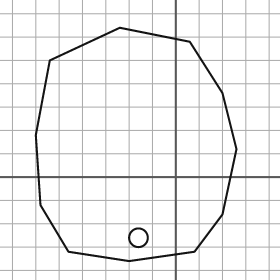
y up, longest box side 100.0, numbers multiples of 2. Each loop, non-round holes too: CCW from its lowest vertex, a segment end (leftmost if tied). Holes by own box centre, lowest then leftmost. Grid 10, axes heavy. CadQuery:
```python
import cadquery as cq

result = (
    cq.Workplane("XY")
    .moveTo(-20.0, -36.0)
    .lineTo(8.0, -32.0)
    .lineTo(20.0, -16.0)
    .lineTo(26.0, 12.0)
    .lineTo(20.0, 36.0)
    .lineTo(6.0, 58.0)
    .lineTo(-24.0, 64.0)
    .lineTo(-54.0, 50.0)
    .lineTo(-60.0, 18.0)
    .lineTo(-58.0, -12.0)
    .lineTo(-46.0, -32.0)
    .close()
    .moveTo(-16.0, -26.0)
    .circle(4.0)
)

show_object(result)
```